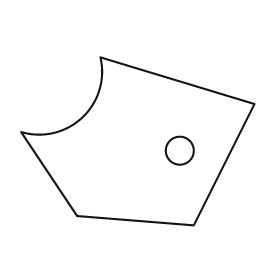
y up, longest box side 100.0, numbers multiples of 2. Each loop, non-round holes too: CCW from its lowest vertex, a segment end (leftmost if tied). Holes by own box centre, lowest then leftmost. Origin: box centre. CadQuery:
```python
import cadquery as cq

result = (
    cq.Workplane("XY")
    .moveTo(24.0, -36.0)
    .lineTo(50.0, 16.0)
    .lineTo(-16.0, 36.0)
    .threePointArc((-24.0, 10.0), (-50.0, 4.0))
    .lineTo(-26.0, -32.0)
    .close()
    .moveTo(18.0, -4.0)
    .circle(6.0)
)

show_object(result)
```